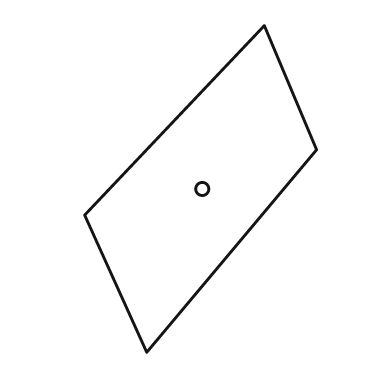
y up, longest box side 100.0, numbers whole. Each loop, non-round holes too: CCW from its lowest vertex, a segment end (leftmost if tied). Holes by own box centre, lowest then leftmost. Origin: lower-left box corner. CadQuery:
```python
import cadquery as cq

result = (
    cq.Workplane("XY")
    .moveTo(19.0, 0.0)
    .lineTo(71.0, 62.0)
    .lineTo(55.0, 100.0)
    .lineTo(0.0, 42.0)
    .close()
    .moveTo(36.0, 50.0)
    .circle(2.0)
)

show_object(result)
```